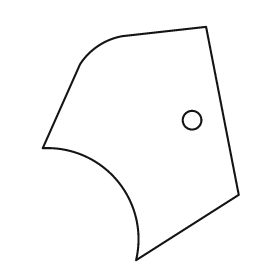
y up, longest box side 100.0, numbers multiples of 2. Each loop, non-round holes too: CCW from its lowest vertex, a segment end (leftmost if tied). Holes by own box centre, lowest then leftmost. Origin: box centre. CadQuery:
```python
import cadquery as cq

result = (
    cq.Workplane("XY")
    .moveTo(-2.0, -50.0)
    .lineTo(42.0, -22.0)
    .lineTo(28.0, 50.0)
    .lineTo(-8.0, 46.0)
    .threePointArc((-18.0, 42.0), (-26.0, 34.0))
    .lineTo(-42.0, -2.0)
    .threePointArc((-10.0, -16.0), (-2.0, -50.0))
    .close()
    .moveTo(22.0, 10.0)
    .circle(4.0)
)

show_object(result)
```